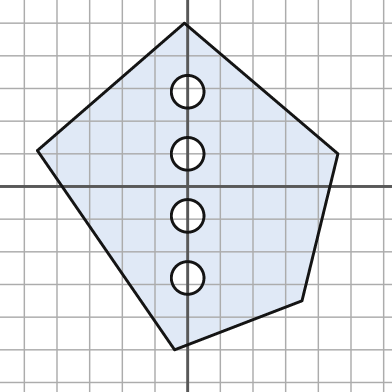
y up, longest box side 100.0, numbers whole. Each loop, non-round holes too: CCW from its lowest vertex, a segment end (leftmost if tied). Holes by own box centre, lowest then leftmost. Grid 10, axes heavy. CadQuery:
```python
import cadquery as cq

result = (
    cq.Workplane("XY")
    .moveTo(-4.0, -50.0)
    .lineTo(35.0, -35.0)
    .lineTo(46.0, 10.0)
    .lineTo(-1.0, 50.0)
    .lineTo(-46.0, 11.0)
    .close()
    .moveTo(0.0, -28.0)
    .circle(5.0)
    .moveTo(0.0, -9.0)
    .circle(5.0)
    .moveTo(0.0, 10.0)
    .circle(5.0)
    .moveTo(0.0, 29.0)
    .circle(5.0)
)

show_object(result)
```